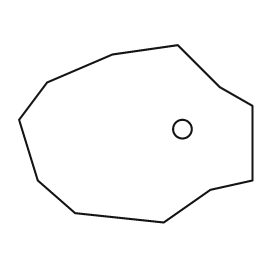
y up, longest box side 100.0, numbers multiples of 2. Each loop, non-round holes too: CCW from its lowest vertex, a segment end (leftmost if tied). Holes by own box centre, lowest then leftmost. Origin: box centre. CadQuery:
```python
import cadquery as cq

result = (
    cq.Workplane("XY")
    .moveTo(12.0, -38.0)
    .lineTo(32.0, -24.0)
    .lineTo(50.0, -20.0)
    .lineTo(50.0, 12.0)
    .lineTo(36.0, 20.0)
    .lineTo(18.0, 38.0)
    .lineTo(-10.0, 34.0)
    .lineTo(-38.0, 22.0)
    .lineTo(-50.0, 6.0)
    .lineTo(-42.0, -20.0)
    .lineTo(-26.0, -34.0)
    .close()
    .moveTo(20.0, 2.0)
    .circle(4.0)
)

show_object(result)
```